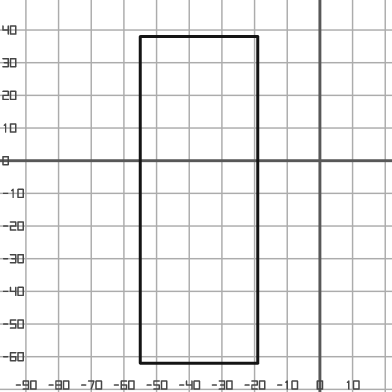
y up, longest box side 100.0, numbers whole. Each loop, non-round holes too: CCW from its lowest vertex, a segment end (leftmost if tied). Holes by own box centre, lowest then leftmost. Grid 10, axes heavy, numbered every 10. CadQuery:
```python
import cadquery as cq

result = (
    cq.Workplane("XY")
    .moveTo(-55.0, -62.0)
    .lineTo(-19.0, -62.0)
    .lineTo(-19.0, 38.0)
    .lineTo(-55.0, 38.0)
    .close()
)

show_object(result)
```